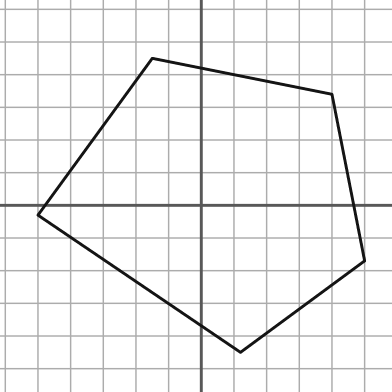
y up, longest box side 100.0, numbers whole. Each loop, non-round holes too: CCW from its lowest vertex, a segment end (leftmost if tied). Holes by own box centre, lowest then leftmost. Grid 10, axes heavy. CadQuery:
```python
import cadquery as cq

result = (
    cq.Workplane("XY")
    .moveTo(12.0, -45.0)
    .lineTo(50.0, -17.0)
    .lineTo(40.0, 34.0)
    .lineTo(-15.0, 45.0)
    .lineTo(-50.0, -3.0)
    .close()
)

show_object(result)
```